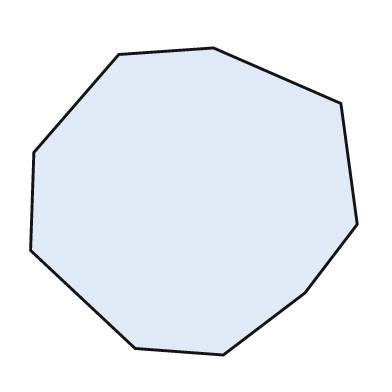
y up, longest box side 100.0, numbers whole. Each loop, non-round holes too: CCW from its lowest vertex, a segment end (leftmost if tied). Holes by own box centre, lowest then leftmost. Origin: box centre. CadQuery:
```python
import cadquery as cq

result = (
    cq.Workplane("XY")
    .moveTo(9.0, -47.0)
    .lineTo(34.0, -28.0)
    .lineTo(50.0, -7.0)
    .lineTo(45.0, 30.0)
    .lineTo(6.0, 47.0)
    .lineTo(-23.0, 45.0)
    .lineTo(-49.0, 15.0)
    .lineTo(-50.0, -15.0)
    .lineTo(-18.0, -45.0)
    .close()
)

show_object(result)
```